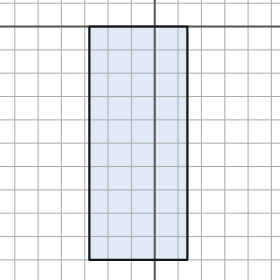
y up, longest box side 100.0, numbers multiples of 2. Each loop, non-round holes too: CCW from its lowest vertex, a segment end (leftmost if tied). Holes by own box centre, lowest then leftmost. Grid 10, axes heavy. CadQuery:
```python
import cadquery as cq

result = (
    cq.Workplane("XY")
    .moveTo(-28.0, -100.0)
    .lineTo(14.0, -100.0)
    .lineTo(14.0, 0.0)
    .lineTo(-28.0, 0.0)
    .close()
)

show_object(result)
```